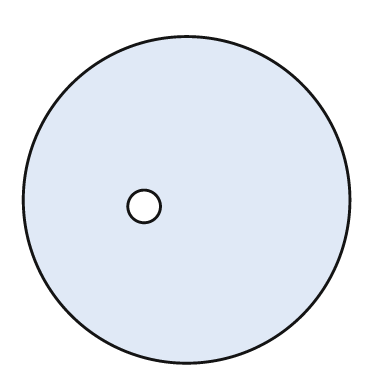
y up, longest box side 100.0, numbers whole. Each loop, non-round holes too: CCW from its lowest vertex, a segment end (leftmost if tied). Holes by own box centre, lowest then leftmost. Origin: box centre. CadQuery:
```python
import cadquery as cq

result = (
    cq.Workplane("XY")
    .moveTo(0.0, 0.0)
    .circle(50.0)
    .moveTo(-13.0, -2.0)
    .circle(5.0)
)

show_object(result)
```